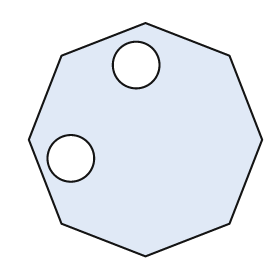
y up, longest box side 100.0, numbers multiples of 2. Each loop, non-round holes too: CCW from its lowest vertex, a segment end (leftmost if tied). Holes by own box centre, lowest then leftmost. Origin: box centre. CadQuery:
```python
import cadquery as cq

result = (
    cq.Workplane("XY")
    .moveTo(0.0, -50.0)
    .lineTo(36.0, -36.0)
    .lineTo(50.0, 0.0)
    .lineTo(36.0, 36.0)
    .lineTo(0.0, 50.0)
    .lineTo(-36.0, 36.0)
    .lineTo(-50.0, 0.0)
    .lineTo(-36.0, -36.0)
    .close()
    .moveTo(-32.0, -8.0)
    .circle(10.0)
    .moveTo(-4.0, 32.0)
    .circle(10.0)
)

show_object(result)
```